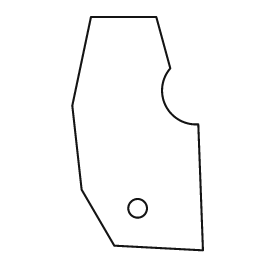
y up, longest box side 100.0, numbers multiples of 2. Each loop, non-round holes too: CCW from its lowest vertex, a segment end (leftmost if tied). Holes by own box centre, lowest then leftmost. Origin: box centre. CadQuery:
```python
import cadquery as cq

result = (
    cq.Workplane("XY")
    .moveTo(28.0, -50.0)
    .lineTo(26.0, 4.0)
    .threePointArc((12.0, 12.0), (14.0, 28.0))
    .lineTo(8.0, 50.0)
    .lineTo(-20.0, 50.0)
    .lineTo(-28.0, 12.0)
    .lineTo(-24.0, -24.0)
    .lineTo(-10.0, -48.0)
    .close()
    .moveTo(0.0, -32.0)
    .circle(4.0)
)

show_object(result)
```